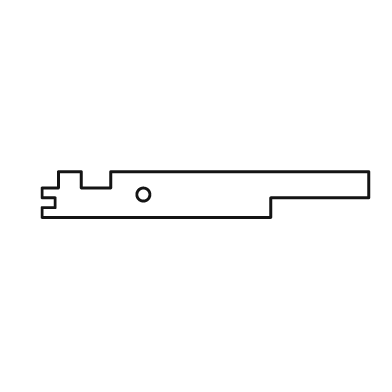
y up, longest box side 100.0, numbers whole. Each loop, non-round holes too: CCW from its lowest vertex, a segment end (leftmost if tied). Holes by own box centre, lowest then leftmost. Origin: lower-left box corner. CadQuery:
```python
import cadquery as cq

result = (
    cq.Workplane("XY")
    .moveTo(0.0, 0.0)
    .lineTo(70.0, 0.0)
    .lineTo(70.0, 6.0)
    .lineTo(100.0, 6.0)
    .lineTo(100.0, 14.0)
    .lineTo(21.0, 14.0)
    .lineTo(21.0, 9.0)
    .lineTo(12.0, 9.0)
    .lineTo(12.0, 14.0)
    .lineTo(5.0, 14.0)
    .lineTo(5.0, 9.0)
    .lineTo(0.0, 9.0)
    .lineTo(0.0, 6.0)
    .lineTo(4.0, 6.0)
    .lineTo(4.0, 3.0)
    .lineTo(0.0, 3.0)
    .close()
    .moveTo(31.0, 7.0)
    .circle(2.0)
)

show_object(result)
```